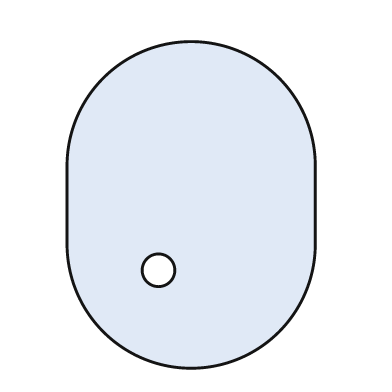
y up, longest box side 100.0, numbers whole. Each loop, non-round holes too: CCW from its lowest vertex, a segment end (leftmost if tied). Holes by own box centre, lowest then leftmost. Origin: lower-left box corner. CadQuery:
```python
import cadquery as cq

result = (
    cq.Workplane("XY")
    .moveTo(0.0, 38.0)
    .threePointArc((38.0, 0.0), (76.0, 38.0))
    .lineTo(76.0, 62.0)
    .threePointArc((38.0, 100.0), (0.0, 62.0))
    .close()
    .moveTo(28.0, 30.0)
    .circle(5.0)
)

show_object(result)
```